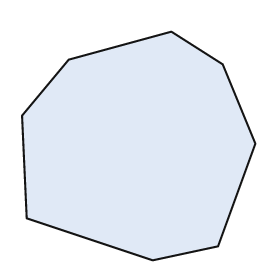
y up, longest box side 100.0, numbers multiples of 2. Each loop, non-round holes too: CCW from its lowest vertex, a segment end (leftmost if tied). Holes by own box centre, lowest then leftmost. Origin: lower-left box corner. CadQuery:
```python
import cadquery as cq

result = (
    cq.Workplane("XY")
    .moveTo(56.0, 0.0)
    .lineTo(84.0, 6.0)
    .lineTo(100.0, 50.0)
    .lineTo(86.0, 84.0)
    .lineTo(64.0, 98.0)
    .lineTo(20.0, 86.0)
    .lineTo(0.0, 62.0)
    .lineTo(2.0, 18.0)
    .close()
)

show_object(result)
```